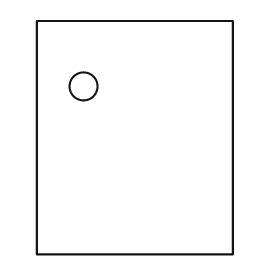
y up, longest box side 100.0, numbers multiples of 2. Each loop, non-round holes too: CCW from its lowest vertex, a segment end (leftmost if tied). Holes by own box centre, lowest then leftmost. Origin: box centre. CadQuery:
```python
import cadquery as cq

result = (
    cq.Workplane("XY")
    .moveTo(-42.0, -50.0)
    .lineTo(42.0, -50.0)
    .lineTo(42.0, 50.0)
    .lineTo(-42.0, 50.0)
    .close()
    .moveTo(-22.0, 22.0)
    .circle(6.0)
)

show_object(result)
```